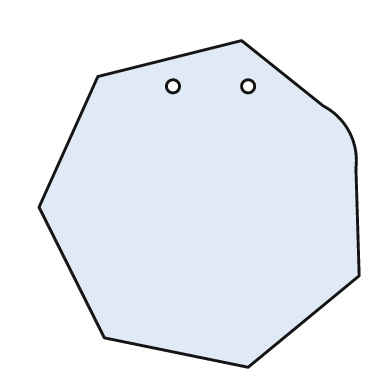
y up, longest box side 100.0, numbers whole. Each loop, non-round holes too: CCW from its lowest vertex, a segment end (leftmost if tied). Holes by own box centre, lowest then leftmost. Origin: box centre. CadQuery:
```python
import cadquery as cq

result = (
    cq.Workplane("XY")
    .moveTo(15.0, -50.0)
    .lineTo(49.0, -22.0)
    .lineTo(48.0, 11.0)
    .threePointArc((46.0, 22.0), (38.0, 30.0))
    .lineTo(13.0, 50.0)
    .lineTo(-31.0, 39.0)
    .lineTo(-49.0, -1.0)
    .lineTo(-29.0, -41.0)
    .close()
    .moveTo(-8.0, 36.0)
    .circle(2.0)
    .moveTo(15.0, 36.0)
    .circle(2.0)
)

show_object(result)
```